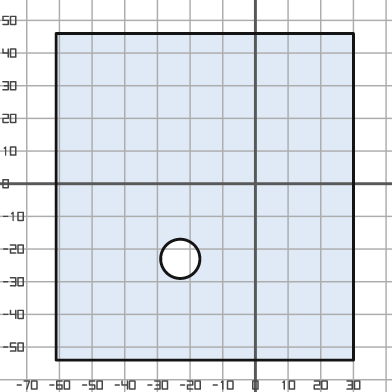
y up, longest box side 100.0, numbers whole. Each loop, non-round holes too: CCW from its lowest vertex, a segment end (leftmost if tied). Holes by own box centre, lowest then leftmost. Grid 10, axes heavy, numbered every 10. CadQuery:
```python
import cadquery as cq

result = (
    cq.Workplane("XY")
    .moveTo(-61.0, -54.0)
    .lineTo(30.0, -54.0)
    .lineTo(30.0, 46.0)
    .lineTo(-61.0, 46.0)
    .close()
    .moveTo(-23.0, -23.0)
    .circle(6.0)
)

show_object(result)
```